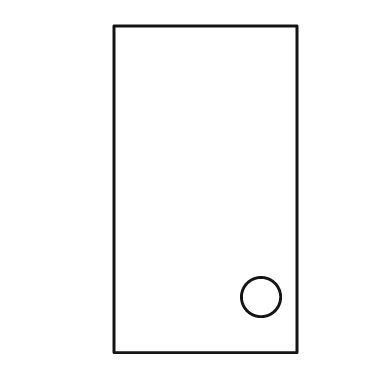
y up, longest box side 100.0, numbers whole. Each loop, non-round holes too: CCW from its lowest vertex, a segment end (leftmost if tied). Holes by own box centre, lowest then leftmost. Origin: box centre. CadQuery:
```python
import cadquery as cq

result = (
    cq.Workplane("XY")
    .moveTo(-28.0, -50.0)
    .lineTo(28.0, -50.0)
    .lineTo(28.0, 50.0)
    .lineTo(-28.0, 50.0)
    .close()
    .moveTo(17.0, -33.0)
    .circle(6.0)
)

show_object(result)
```